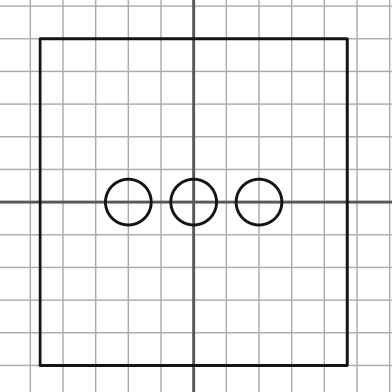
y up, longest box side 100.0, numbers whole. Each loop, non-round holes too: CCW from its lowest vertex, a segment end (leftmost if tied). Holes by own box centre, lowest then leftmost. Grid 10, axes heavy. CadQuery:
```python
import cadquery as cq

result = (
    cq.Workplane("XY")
    .moveTo(-47.0, -50.0)
    .lineTo(47.0, -50.0)
    .lineTo(47.0, 50.0)
    .lineTo(-47.0, 50.0)
    .close()
    .moveTo(-20.0, 0.0)
    .circle(7.0)
    .moveTo(0.0, 0.0)
    .circle(7.0)
    .moveTo(20.0, 0.0)
    .circle(7.0)
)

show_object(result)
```